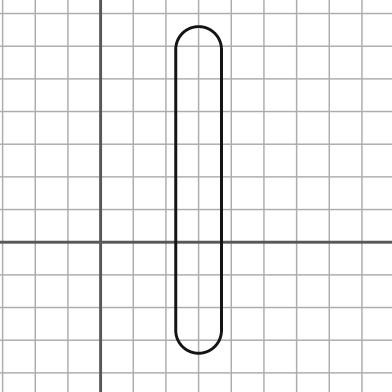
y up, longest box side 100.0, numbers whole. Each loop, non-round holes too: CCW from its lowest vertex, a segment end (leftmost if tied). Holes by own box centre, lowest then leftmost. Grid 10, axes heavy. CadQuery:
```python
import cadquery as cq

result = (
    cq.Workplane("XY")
    .moveTo(23.0, -27.0)
    .threePointArc((30.0, -34.0), (37.0, -27.0))
    .lineTo(37.0, 59.0)
    .threePointArc((30.0, 66.0), (23.0, 59.0))
    .close()
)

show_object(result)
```